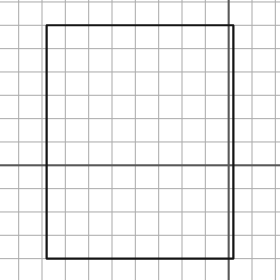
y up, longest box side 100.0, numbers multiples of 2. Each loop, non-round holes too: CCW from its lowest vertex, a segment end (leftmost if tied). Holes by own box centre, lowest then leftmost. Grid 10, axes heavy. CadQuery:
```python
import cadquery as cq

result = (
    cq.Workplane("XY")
    .moveTo(-78.0, -40.0)
    .lineTo(2.0, -40.0)
    .lineTo(2.0, 60.0)
    .lineTo(-78.0, 60.0)
    .close()
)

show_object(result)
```